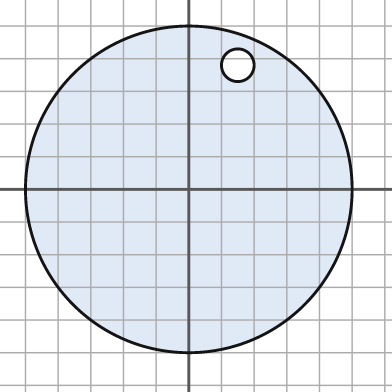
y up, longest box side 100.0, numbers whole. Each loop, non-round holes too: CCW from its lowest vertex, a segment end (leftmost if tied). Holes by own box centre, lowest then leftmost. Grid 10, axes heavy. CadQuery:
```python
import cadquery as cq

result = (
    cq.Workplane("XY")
    .moveTo(0.0, 0.0)
    .circle(50.0)
    .moveTo(15.0, 38.0)
    .circle(5.0)
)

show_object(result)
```